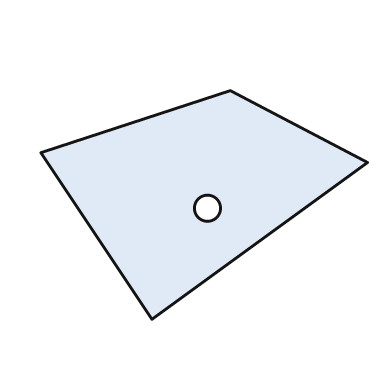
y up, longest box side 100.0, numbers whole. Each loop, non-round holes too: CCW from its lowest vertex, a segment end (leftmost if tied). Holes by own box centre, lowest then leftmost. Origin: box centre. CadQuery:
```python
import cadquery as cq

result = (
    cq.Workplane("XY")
    .moveTo(-16.0, -35.0)
    .lineTo(50.0, 13.0)
    .lineTo(8.0, 35.0)
    .lineTo(-50.0, 16.0)
    .close()
    .moveTo(1.0, -1.0)
    .circle(4.0)
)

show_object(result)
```